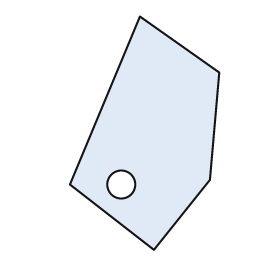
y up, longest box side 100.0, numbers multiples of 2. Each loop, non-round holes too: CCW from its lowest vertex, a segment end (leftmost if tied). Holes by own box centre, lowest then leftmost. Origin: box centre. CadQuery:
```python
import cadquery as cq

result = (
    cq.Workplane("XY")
    .moveTo(4.0, -50.0)
    .lineTo(28.0, -20.0)
    .lineTo(32.0, 26.0)
    .lineTo(-2.0, 50.0)
    .lineTo(-32.0, -22.0)
    .close()
    .moveTo(-10.0, -22.0)
    .circle(6.0)
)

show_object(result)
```